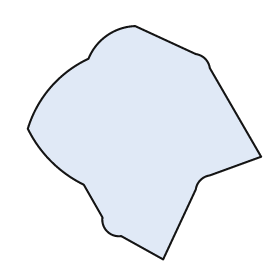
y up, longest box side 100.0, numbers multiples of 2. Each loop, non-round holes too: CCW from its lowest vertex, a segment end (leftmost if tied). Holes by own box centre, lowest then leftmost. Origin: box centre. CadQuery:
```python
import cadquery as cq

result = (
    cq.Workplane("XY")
    .moveTo(8.0, -50.0)
    .lineTo(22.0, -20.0)
    .threePointArc((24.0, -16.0), (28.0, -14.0))
    .lineTo(50.0, -6.0)
    .lineTo(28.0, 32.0)
    .threePointArc((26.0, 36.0), (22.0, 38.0))
    .lineTo(-4.0, 50.0)
    .threePointArc((-16.0, 46.0), (-24.0, 36.0))
    .threePointArc((-40.0, 24.0), (-50.0, 6.0))
    .threePointArc((-40.0, -8.0), (-26.0, -18.0))
    .lineTo(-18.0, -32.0)
    .threePointArc((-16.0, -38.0), (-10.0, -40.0))
    .close()
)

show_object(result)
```